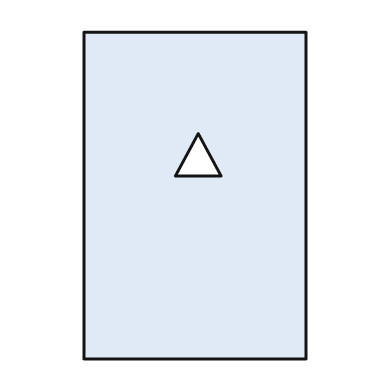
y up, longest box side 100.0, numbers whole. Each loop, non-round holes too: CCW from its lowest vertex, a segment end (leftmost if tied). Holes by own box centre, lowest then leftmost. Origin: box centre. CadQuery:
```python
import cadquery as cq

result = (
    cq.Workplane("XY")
    .moveTo(-34.0, -50.0)
    .lineTo(34.0, -50.0)
    .lineTo(34.0, 50.0)
    .lineTo(-34.0, 50.0)
    .close()
    .moveTo(-6.0, 6.0)
    .lineTo(8.0, 6.0)
    .lineTo(1.0, 19.0)
    .close()
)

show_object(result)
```